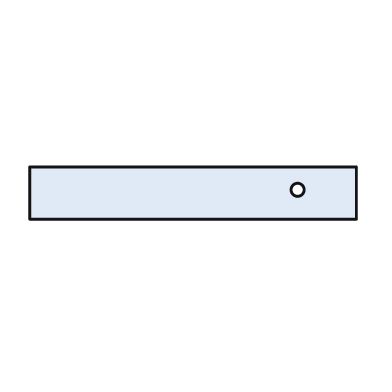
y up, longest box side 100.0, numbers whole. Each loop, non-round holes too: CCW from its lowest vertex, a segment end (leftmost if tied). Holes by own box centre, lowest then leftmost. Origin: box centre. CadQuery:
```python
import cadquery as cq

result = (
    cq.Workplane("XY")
    .moveTo(-50.0, -8.0)
    .lineTo(50.0, -8.0)
    .lineTo(50.0, 8.0)
    .lineTo(-50.0, 8.0)
    .close()
    .moveTo(32.0, 1.0)
    .circle(2.0)
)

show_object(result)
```